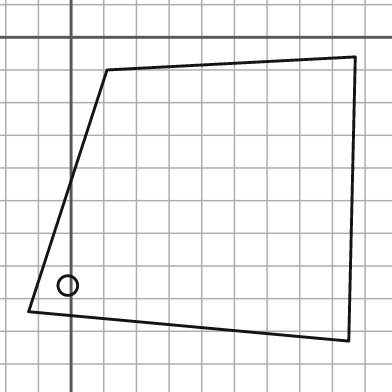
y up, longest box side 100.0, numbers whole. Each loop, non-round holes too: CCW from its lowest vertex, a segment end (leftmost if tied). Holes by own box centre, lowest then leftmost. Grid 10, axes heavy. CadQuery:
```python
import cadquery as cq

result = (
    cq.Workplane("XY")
    .moveTo(85.0, -93.0)
    .lineTo(87.0, -6.0)
    .lineTo(11.0, -10.0)
    .lineTo(-13.0, -84.0)
    .close()
    .moveTo(-1.0, -76.0)
    .circle(3.0)
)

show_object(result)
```